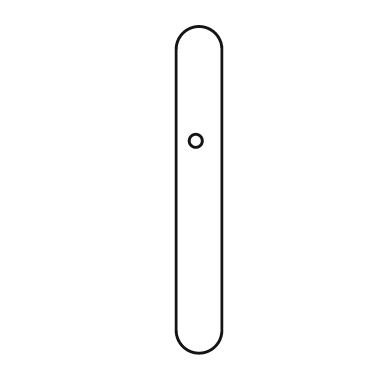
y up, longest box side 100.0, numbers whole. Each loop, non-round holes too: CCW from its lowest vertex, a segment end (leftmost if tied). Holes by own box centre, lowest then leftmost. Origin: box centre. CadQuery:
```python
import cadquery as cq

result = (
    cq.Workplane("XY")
    .moveTo(-7.0, -43.0)
    .threePointArc((0.0, -50.0), (7.0, -43.0))
    .lineTo(7.0, 43.0)
    .threePointArc((0.0, 50.0), (-7.0, 43.0))
    .close()
    .moveTo(-1.0, 15.0)
    .circle(2.0)
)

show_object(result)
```